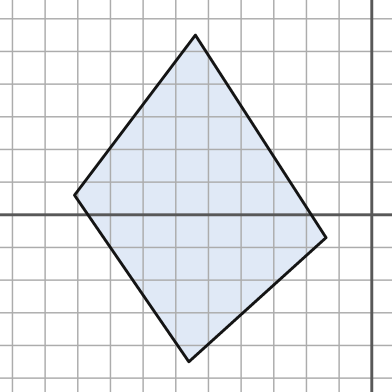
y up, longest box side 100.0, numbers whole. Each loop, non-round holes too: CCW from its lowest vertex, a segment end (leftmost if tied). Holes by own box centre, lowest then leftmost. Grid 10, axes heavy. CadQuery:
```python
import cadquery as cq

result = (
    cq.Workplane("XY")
    .moveTo(-56.0, -45.0)
    .lineTo(-14.0, -7.0)
    .lineTo(-54.0, 55.0)
    .lineTo(-91.0, 6.0)
    .close()
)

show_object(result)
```